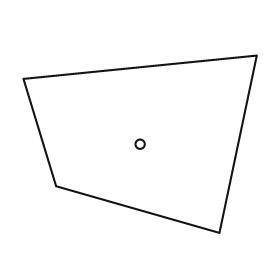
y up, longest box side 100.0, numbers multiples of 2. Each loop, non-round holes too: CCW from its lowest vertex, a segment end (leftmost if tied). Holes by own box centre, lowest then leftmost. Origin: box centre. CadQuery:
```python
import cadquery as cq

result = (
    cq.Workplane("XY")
    .moveTo(34.0, -38.0)
    .lineTo(50.0, 38.0)
    .lineTo(-50.0, 28.0)
    .lineTo(-36.0, -18.0)
    .close()
    .moveTo(0.0, 0.0)
    .circle(2.0)
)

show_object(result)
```